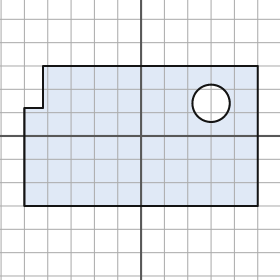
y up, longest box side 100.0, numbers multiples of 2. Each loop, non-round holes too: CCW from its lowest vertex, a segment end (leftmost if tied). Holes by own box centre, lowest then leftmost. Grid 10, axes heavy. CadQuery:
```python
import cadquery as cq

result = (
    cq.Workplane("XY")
    .moveTo(-50.0, -30.0)
    .lineTo(50.0, -30.0)
    .lineTo(50.0, 30.0)
    .lineTo(-42.0, 30.0)
    .lineTo(-42.0, 12.0)
    .lineTo(-50.0, 12.0)
    .close()
    .moveTo(30.0, 14.0)
    .circle(8.0)
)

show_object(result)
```